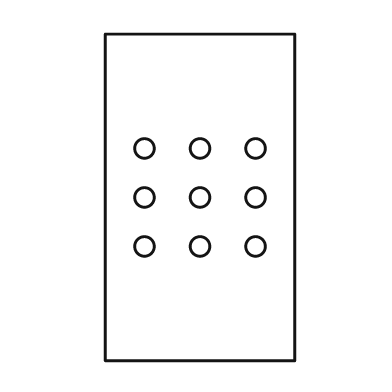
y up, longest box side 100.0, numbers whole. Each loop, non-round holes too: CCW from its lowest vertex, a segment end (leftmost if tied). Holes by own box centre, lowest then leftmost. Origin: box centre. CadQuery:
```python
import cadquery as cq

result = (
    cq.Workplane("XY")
    .moveTo(-29.0, -50.0)
    .lineTo(29.0, -50.0)
    .lineTo(29.0, 50.0)
    .lineTo(-29.0, 50.0)
    .close()
    .moveTo(-17.0, -15.0)
    .circle(3.0)
    .moveTo(0.0, -15.0)
    .circle(3.0)
    .moveTo(17.0, -15.0)
    .circle(3.0)
    .moveTo(-17.0, 0.0)
    .circle(3.0)
    .moveTo(0.0, 0.0)
    .circle(3.0)
    .moveTo(17.0, 0.0)
    .circle(3.0)
    .moveTo(-17.0, 15.0)
    .circle(3.0)
    .moveTo(0.0, 15.0)
    .circle(3.0)
    .moveTo(17.0, 15.0)
    .circle(3.0)
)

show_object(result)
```